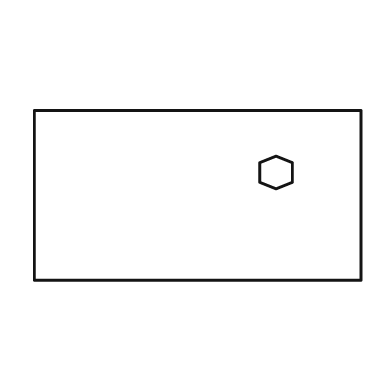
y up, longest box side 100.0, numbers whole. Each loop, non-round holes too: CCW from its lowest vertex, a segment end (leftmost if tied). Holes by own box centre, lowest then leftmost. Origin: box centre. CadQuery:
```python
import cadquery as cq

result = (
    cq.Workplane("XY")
    .moveTo(-50.0, -26.0)
    .lineTo(50.0, -26.0)
    .lineTo(50.0, 26.0)
    .lineTo(-50.0, 26.0)
    .close()
    .moveTo(24.0, 2.0)
    .lineTo(29.0, 4.0)
    .lineTo(29.0, 10.0)
    .lineTo(24.0, 12.0)
    .lineTo(19.0, 10.0)
    .lineTo(19.0, 4.0)
    .close()
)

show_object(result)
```